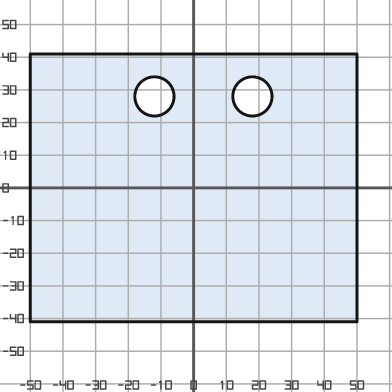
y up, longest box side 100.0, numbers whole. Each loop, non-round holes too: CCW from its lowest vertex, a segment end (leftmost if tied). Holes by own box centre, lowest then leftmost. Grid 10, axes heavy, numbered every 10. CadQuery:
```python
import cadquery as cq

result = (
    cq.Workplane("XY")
    .moveTo(-50.0, -41.0)
    .lineTo(50.0, -41.0)
    .lineTo(50.0, 41.0)
    .lineTo(-50.0, 41.0)
    .close()
    .moveTo(-12.0, 28.0)
    .circle(6.0)
    .moveTo(18.0, 28.0)
    .circle(6.0)
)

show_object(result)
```